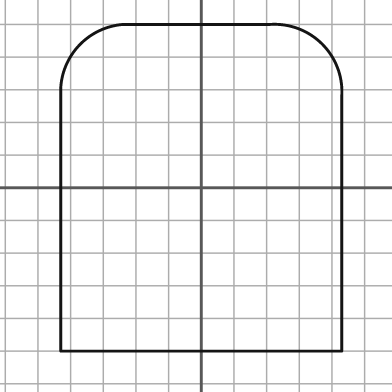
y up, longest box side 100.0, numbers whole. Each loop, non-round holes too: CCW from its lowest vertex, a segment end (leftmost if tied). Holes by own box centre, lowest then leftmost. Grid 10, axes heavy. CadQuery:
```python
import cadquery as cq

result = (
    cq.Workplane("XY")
    .moveTo(-43.0, -50.0)
    .lineTo(43.0, -50.0)
    .lineTo(43.0, 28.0)
    .threePointArc((37.0, 44.0), (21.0, 50.0))
    .lineTo(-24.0, 50.0)
    .threePointArc((-37.0, 44.0), (-43.0, 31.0))
    .close()
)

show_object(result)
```